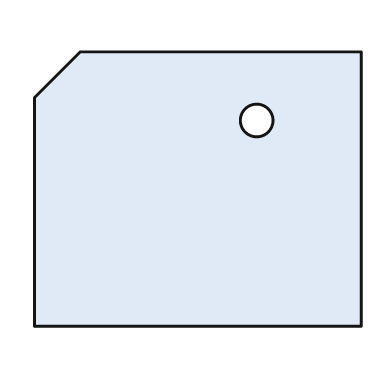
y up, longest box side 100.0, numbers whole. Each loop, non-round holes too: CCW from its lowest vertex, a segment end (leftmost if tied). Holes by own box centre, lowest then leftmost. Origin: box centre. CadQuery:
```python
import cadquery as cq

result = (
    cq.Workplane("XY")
    .moveTo(-50.0, -42.0)
    .lineTo(50.0, -42.0)
    .lineTo(50.0, 42.0)
    .lineTo(-36.0, 42.0)
    .lineTo(-50.0, 28.0)
    .close()
    .moveTo(18.0, 21.0)
    .circle(5.0)
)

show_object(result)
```